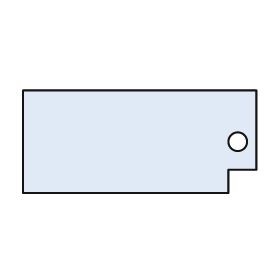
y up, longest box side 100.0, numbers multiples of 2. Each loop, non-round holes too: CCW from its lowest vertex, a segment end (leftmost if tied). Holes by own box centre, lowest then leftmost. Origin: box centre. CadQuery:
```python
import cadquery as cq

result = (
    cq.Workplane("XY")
    .moveTo(-50.0, -22.0)
    .lineTo(38.0, -22.0)
    .lineTo(38.0, -12.0)
    .lineTo(50.0, -12.0)
    .lineTo(50.0, 22.0)
    .lineTo(-50.0, 22.0)
    .close()
    .moveTo(42.0, 0.0)
    .circle(4.0)
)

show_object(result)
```